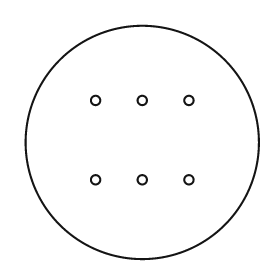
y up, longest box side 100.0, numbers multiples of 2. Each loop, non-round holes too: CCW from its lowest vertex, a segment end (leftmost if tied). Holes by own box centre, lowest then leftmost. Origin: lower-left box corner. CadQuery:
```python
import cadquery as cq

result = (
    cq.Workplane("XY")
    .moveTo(50.0, 50.0)
    .circle(50.0)
    .moveTo(30.0, 34.0)
    .circle(2.0)
    .moveTo(50.0, 34.0)
    .circle(2.0)
    .moveTo(70.0, 34.0)
    .circle(2.0)
    .moveTo(30.0, 68.0)
    .circle(2.0)
    .moveTo(50.0, 68.0)
    .circle(2.0)
    .moveTo(70.0, 68.0)
    .circle(2.0)
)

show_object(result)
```